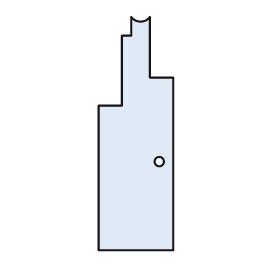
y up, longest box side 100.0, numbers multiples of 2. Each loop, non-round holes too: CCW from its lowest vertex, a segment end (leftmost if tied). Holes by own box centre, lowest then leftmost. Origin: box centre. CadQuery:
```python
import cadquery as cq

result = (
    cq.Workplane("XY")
    .moveTo(-16.0, -50.0)
    .lineTo(16.0, -50.0)
    .lineTo(16.0, 24.0)
    .lineTo(6.0, 24.0)
    .lineTo(6.0, 50.0)
    .threePointArc((2.0, 48.0), (-2.0, 50.0))
    .lineTo(-2.0, 42.0)
    .lineTo(-6.0, 42.0)
    .lineTo(-6.0, 12.0)
    .lineTo(-16.0, 12.0)
    .close()
    .moveTo(10.0, -12.0)
    .circle(2.0)
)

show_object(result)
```